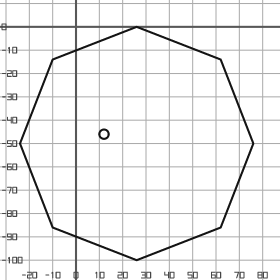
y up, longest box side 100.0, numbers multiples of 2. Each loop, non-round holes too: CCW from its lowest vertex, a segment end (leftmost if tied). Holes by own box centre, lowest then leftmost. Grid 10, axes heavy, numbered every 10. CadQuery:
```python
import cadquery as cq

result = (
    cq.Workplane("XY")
    .moveTo(26.0, -100.0)
    .lineTo(62.0, -86.0)
    .lineTo(76.0, -50.0)
    .lineTo(62.0, -14.0)
    .lineTo(26.0, 0.0)
    .lineTo(-10.0, -14.0)
    .lineTo(-24.0, -50.0)
    .lineTo(-10.0, -86.0)
    .close()
    .moveTo(12.0, -46.0)
    .circle(2.0)
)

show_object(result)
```